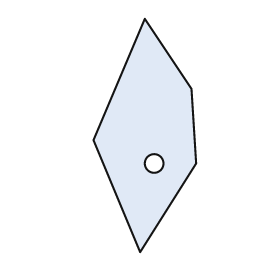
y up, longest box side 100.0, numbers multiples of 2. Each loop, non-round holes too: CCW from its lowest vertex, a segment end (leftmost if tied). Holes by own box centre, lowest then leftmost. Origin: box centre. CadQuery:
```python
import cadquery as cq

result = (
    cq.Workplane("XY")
    .moveTo(-2.0, -50.0)
    .lineTo(22.0, -12.0)
    .lineTo(20.0, 20.0)
    .lineTo(0.0, 50.0)
    .lineTo(-22.0, -2.0)
    .close()
    .moveTo(4.0, -12.0)
    .circle(4.0)
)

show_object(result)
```